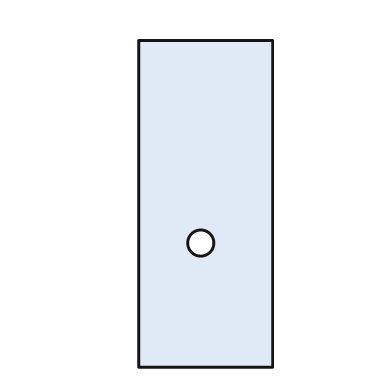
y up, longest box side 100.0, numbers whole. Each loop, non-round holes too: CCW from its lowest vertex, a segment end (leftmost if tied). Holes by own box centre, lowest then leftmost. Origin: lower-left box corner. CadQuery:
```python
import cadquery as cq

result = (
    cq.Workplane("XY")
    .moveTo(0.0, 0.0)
    .lineTo(41.0, 0.0)
    .lineTo(41.0, 100.0)
    .lineTo(0.0, 100.0)
    .close()
    .moveTo(19.0, 38.0)
    .circle(4.0)
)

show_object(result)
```